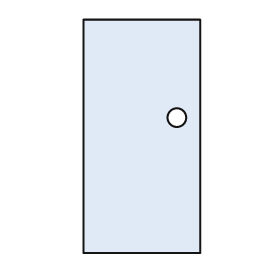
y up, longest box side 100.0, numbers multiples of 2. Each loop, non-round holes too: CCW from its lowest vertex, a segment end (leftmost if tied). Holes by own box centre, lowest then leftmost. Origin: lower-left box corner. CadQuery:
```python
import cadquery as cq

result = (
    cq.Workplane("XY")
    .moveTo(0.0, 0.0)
    .lineTo(50.0, 0.0)
    .lineTo(50.0, 100.0)
    .lineTo(0.0, 100.0)
    .close()
    .moveTo(40.0, 58.0)
    .circle(4.0)
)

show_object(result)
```